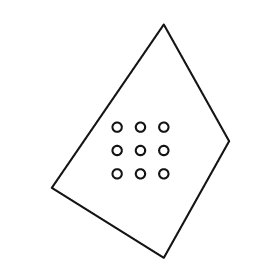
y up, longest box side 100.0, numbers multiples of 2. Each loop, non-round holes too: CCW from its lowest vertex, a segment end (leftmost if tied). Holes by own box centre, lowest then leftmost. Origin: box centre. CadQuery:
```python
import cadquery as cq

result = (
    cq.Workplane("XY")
    .moveTo(10.0, -50.0)
    .lineTo(38.0, 0.0)
    .lineTo(10.0, 50.0)
    .lineTo(-38.0, -20.0)
    .close()
    .moveTo(-10.0, -14.0)
    .circle(2.0)
    .moveTo(0.0, -14.0)
    .circle(2.0)
    .moveTo(10.0, -14.0)
    .circle(2.0)
    .moveTo(-10.0, -4.0)
    .circle(2.0)
    .moveTo(0.0, -4.0)
    .circle(2.0)
    .moveTo(10.0, -4.0)
    .circle(2.0)
    .moveTo(-10.0, 6.0)
    .circle(2.0)
    .moveTo(0.0, 6.0)
    .circle(2.0)
    .moveTo(10.0, 6.0)
    .circle(2.0)
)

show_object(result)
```